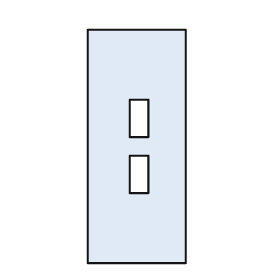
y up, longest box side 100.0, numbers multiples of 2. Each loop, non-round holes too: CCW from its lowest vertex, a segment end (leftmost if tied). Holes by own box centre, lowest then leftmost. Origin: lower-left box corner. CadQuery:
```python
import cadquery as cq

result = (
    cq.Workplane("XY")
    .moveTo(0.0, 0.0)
    .lineTo(42.0, 0.0)
    .lineTo(42.0, 100.0)
    .lineTo(0.0, 100.0)
    .close()
    .moveTo(18.0, 30.0)
    .lineTo(26.0, 30.0)
    .lineTo(26.0, 46.0)
    .lineTo(18.0, 46.0)
    .close()
    .moveTo(18.0, 54.0)
    .lineTo(26.0, 54.0)
    .lineTo(26.0, 70.0)
    .lineTo(18.0, 70.0)
    .close()
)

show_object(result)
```